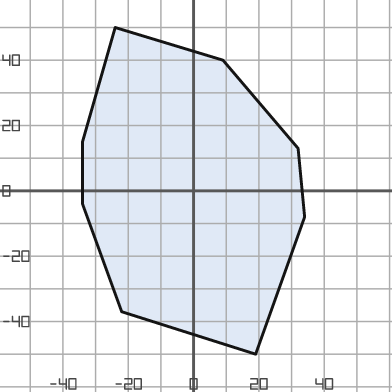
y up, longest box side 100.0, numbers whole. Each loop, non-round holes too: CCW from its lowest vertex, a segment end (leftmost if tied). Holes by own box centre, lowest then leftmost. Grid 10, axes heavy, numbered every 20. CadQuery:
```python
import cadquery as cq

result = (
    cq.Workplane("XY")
    .moveTo(19.0, -50.0)
    .lineTo(34.0, -8.0)
    .lineTo(32.0, 13.0)
    .lineTo(9.0, 40.0)
    .lineTo(-24.0, 50.0)
    .lineTo(-34.0, 15.0)
    .lineTo(-34.0, -4.0)
    .lineTo(-22.0, -37.0)
    .close()
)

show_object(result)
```